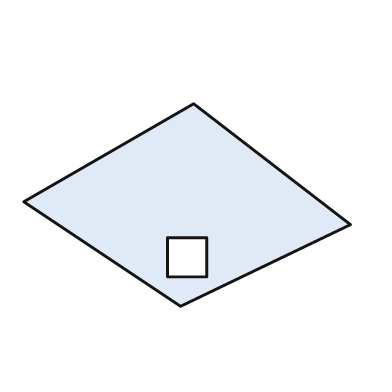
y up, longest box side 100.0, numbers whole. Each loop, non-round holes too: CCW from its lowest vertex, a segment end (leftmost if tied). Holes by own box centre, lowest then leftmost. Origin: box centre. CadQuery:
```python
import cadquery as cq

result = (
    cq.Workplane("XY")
    .moveTo(-2.0, -31.0)
    .lineTo(50.0, -6.0)
    .lineTo(2.0, 31.0)
    .lineTo(-50.0, 1.0)
    .close()
    .moveTo(-6.0, -22.0)
    .lineTo(6.0, -22.0)
    .lineTo(6.0, -10.0)
    .lineTo(-6.0, -10.0)
    .close()
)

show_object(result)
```